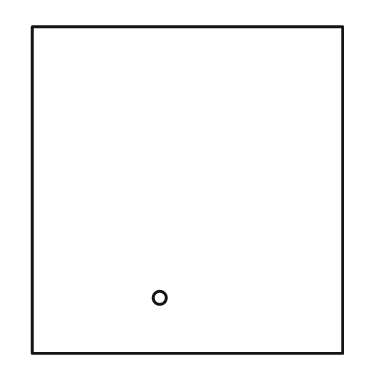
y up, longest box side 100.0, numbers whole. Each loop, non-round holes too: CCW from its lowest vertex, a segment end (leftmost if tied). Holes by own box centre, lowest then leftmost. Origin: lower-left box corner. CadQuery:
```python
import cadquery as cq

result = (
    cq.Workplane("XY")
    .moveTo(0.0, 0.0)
    .lineTo(95.0, 0.0)
    .lineTo(95.0, 100.0)
    .lineTo(0.0, 100.0)
    .close()
    .moveTo(39.0, 17.0)
    .circle(2.0)
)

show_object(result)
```